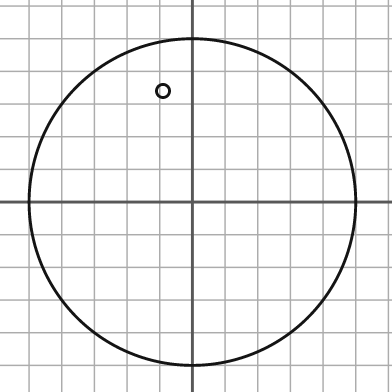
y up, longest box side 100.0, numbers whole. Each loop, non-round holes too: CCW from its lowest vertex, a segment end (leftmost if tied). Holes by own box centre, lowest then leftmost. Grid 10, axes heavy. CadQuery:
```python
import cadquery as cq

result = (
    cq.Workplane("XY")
    .moveTo(0.0, 0.0)
    .circle(50.0)
    .moveTo(-9.0, 34.0)
    .circle(2.0)
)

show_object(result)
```